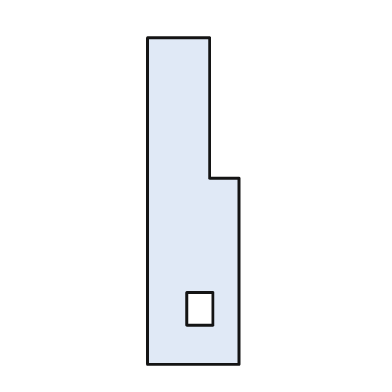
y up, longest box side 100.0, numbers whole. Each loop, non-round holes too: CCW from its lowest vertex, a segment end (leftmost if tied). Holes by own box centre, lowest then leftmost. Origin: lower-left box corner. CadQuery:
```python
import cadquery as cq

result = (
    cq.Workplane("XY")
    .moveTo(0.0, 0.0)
    .lineTo(28.0, 0.0)
    .lineTo(28.0, 57.0)
    .lineTo(19.0, 57.0)
    .lineTo(19.0, 100.0)
    .lineTo(0.0, 100.0)
    .close()
    .moveTo(12.0, 12.0)
    .lineTo(20.0, 12.0)
    .lineTo(20.0, 22.0)
    .lineTo(12.0, 22.0)
    .close()
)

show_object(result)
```